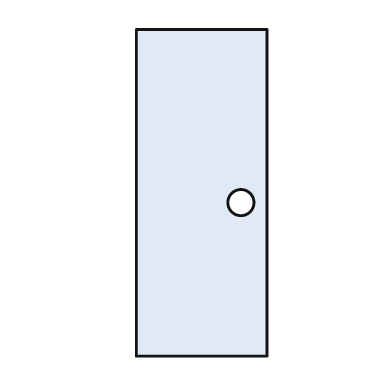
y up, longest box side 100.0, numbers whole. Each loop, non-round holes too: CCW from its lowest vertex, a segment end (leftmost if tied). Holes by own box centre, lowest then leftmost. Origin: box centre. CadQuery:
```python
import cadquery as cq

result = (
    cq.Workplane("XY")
    .moveTo(-20.0, -50.0)
    .lineTo(20.0, -50.0)
    .lineTo(20.0, 50.0)
    .lineTo(-20.0, 50.0)
    .close()
    .moveTo(12.0, -3.0)
    .circle(4.0)
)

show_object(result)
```